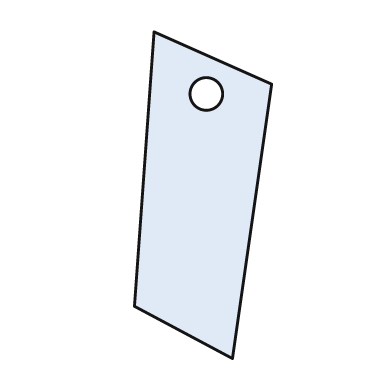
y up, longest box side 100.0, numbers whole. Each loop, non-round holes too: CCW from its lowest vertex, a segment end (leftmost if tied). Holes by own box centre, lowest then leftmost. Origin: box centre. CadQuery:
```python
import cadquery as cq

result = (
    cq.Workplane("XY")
    .moveTo(9.0, -50.0)
    .lineTo(21.0, 34.0)
    .lineTo(-15.0, 50.0)
    .lineTo(-21.0, -34.0)
    .close()
    .moveTo(1.0, 31.0)
    .circle(5.0)
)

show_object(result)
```